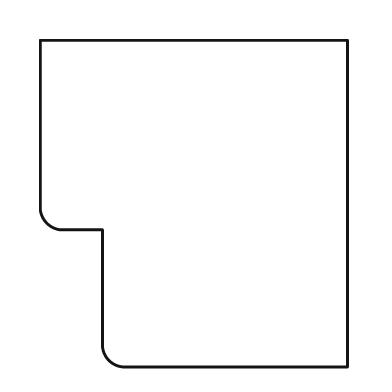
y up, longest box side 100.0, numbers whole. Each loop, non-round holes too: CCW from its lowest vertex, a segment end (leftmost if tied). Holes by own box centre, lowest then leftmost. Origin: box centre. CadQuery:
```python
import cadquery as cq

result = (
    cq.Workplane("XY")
    .moveTo(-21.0, -50.0)
    .lineTo(47.0, -50.0)
    .lineTo(47.0, 50.0)
    .lineTo(-47.0, 50.0)
    .lineTo(-47.0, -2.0)
    .threePointArc((-45.0, -6.0), (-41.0, -8.0))
    .lineTo(-28.0, -8.0)
    .lineTo(-28.0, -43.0)
    .threePointArc((-26.0, -48.0), (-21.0, -50.0))
    .close()
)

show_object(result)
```